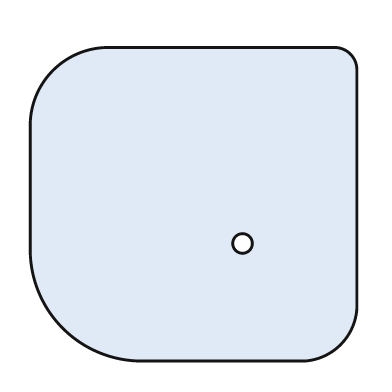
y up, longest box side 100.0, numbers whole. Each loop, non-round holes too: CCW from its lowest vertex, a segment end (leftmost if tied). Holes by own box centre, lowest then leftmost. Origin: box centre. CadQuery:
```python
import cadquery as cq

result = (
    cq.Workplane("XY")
    .moveTo(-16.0, -48.0)
    .lineTo(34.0, -48.0)
    .threePointArc((45.0, -43.0), (50.0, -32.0))
    .lineTo(50.0, 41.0)
    .threePointArc((48.0, 46.0), (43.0, 48.0))
    .lineTo(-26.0, 48.0)
    .threePointArc((-43.0, 41.0), (-50.0, 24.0))
    .lineTo(-50.0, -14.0)
    .threePointArc((-40.0, -38.0), (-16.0, -48.0))
    .close()
    .moveTo(15.0, -12.0)
    .circle(3.0)
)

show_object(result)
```